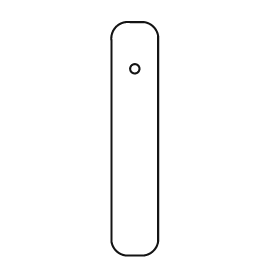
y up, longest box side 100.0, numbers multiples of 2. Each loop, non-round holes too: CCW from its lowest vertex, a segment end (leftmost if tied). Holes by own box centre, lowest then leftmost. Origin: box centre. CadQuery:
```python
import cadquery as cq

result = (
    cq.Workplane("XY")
    .moveTo(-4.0, -50.0)
    .lineTo(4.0, -50.0)
    .threePointArc((8.0, -48.0), (10.0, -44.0))
    .lineTo(10.0, 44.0)
    .threePointArc((8.0, 48.0), (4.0, 50.0))
    .lineTo(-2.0, 50.0)
    .threePointArc((-8.0, 48.0), (-10.0, 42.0))
    .lineTo(-10.0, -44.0)
    .threePointArc((-8.0, -48.0), (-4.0, -50.0))
    .close()
    .moveTo(0.0, 30.0)
    .circle(2.0)
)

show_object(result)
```